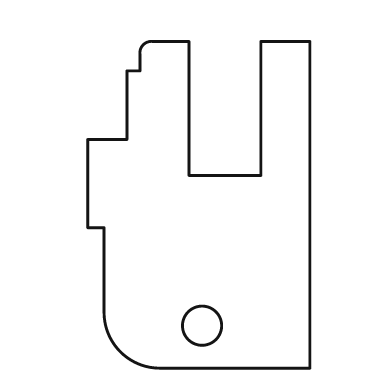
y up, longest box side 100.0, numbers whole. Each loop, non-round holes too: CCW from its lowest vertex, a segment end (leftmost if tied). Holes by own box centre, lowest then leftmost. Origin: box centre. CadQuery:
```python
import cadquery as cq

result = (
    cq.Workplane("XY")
    .moveTo(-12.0, -50.0)
    .lineTo(34.0, -50.0)
    .lineTo(34.0, 50.0)
    .lineTo(19.0, 50.0)
    .lineTo(19.0, 9.0)
    .lineTo(-3.0, 9.0)
    .lineTo(-3.0, 50.0)
    .lineTo(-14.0, 50.0)
    .threePointArc((-17.0, 49.0), (-18.0, 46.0))
    .lineTo(-18.0, 41.0)
    .lineTo(-22.0, 41.0)
    .lineTo(-22.0, 20.0)
    .lineTo(-34.0, 20.0)
    .lineTo(-34.0, -7.0)
    .lineTo(-29.0, -7.0)
    .lineTo(-29.0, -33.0)
    .threePointArc((-24.0, -45.0), (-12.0, -50.0))
    .close()
    .moveTo(1.0, -37.0)
    .circle(6.0)
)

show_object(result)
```